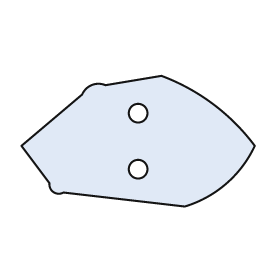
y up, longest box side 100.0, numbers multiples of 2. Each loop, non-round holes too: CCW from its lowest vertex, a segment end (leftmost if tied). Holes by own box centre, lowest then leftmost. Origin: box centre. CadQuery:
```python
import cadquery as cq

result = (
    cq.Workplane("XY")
    .moveTo(20.0, -28.0)
    .threePointArc((38.0, -18.0), (50.0, -2.0))
    .threePointArc((32.0, 16.0), (10.0, 28.0))
    .lineTo(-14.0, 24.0)
    .threePointArc((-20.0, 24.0), (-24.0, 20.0))
    .lineTo(-50.0, -2.0)
    .lineTo(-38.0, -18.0)
    .threePointArc((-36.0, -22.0), (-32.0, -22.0))
    .close()
    .moveTo(0.0, -12.0)
    .circle(4.0)
    .moveTo(0.0, 12.0)
    .circle(4.0)
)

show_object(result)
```